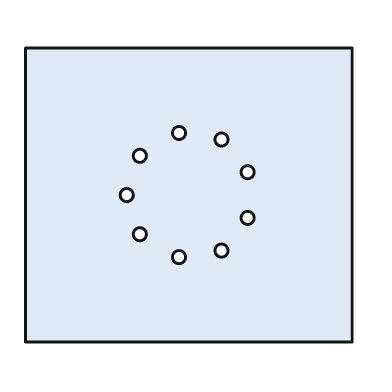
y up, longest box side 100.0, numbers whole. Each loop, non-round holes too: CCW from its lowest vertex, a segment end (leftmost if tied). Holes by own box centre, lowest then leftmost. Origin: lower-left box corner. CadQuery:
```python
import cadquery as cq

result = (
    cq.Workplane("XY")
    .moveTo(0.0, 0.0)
    .lineTo(100.0, 0.0)
    .lineTo(100.0, 90.0)
    .lineTo(0.0, 90.0)
    .close()
    .moveTo(47.0, 26.0)
    .circle(2.0)
    .moveTo(60.0, 28.0)
    .circle(2.0)
    .moveTo(35.0, 33.0)
    .circle(2.0)
    .moveTo(68.0, 38.0)
    .circle(2.0)
    .moveTo(31.0, 45.0)
    .circle(2.0)
    .moveTo(68.0, 52.0)
    .circle(2.0)
    .moveTo(35.0, 57.0)
    .circle(2.0)
    .moveTo(60.0, 62.0)
    .circle(2.0)
    .moveTo(47.0, 64.0)
    .circle(2.0)
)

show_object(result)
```